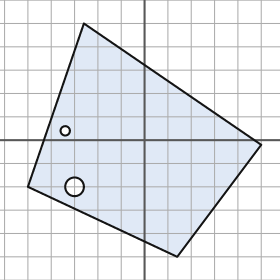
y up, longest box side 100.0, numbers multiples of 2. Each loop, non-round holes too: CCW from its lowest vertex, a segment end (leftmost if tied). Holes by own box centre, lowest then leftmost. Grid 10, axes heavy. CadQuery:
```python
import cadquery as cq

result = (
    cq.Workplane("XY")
    .moveTo(14.0, -50.0)
    .lineTo(50.0, -2.0)
    .lineTo(-26.0, 50.0)
    .lineTo(-50.0, -20.0)
    .close()
    .moveTo(-30.0, -20.0)
    .circle(4.0)
    .moveTo(-34.0, 4.0)
    .circle(2.0)
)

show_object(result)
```